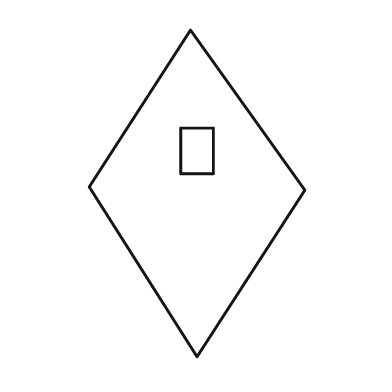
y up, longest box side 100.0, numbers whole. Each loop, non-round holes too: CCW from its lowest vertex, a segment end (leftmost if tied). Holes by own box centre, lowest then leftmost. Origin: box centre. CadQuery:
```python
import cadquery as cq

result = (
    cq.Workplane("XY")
    .moveTo(0.0, -50.0)
    .lineTo(33.0, 1.0)
    .lineTo(-2.0, 50.0)
    .lineTo(-33.0, 2.0)
    .close()
    .moveTo(-5.0, 6.0)
    .lineTo(5.0, 6.0)
    .lineTo(5.0, 20.0)
    .lineTo(-5.0, 20.0)
    .close()
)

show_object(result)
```